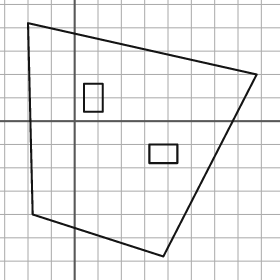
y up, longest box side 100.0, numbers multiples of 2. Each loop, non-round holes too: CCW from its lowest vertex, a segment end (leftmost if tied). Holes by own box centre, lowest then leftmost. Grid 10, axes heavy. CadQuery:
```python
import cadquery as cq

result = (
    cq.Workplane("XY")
    .moveTo(38.0, -58.0)
    .lineTo(78.0, 20.0)
    .lineTo(-20.0, 42.0)
    .lineTo(-18.0, -40.0)
    .close()
    .moveTo(32.0, -18.0)
    .lineTo(44.0, -18.0)
    .lineTo(44.0, -10.0)
    .lineTo(32.0, -10.0)
    .close()
    .moveTo(4.0, 4.0)
    .lineTo(12.0, 4.0)
    .lineTo(12.0, 16.0)
    .lineTo(4.0, 16.0)
    .close()
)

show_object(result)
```